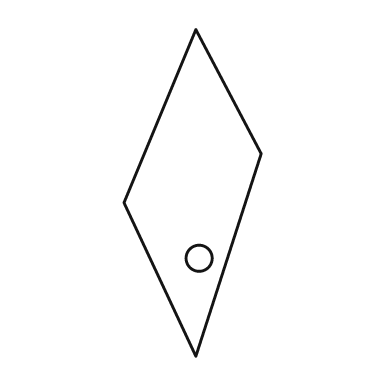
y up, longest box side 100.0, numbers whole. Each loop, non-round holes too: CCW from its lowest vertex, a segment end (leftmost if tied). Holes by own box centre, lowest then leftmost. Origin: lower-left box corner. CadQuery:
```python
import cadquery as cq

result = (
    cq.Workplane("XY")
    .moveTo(22.0, 0.0)
    .lineTo(42.0, 62.0)
    .lineTo(22.0, 100.0)
    .lineTo(0.0, 47.0)
    .close()
    .moveTo(23.0, 30.0)
    .circle(4.0)
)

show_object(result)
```